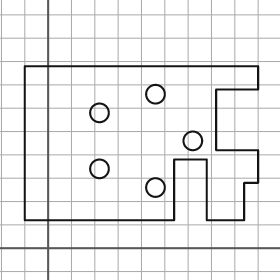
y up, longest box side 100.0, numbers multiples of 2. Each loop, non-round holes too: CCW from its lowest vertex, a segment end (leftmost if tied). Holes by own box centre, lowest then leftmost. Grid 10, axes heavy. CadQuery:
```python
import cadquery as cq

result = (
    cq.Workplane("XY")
    .moveTo(-10.0, 12.0)
    .lineTo(54.0, 12.0)
    .lineTo(54.0, 38.0)
    .lineTo(68.0, 38.0)
    .lineTo(68.0, 12.0)
    .lineTo(84.0, 12.0)
    .lineTo(84.0, 28.0)
    .lineTo(90.0, 28.0)
    .lineTo(90.0, 42.0)
    .lineTo(72.0, 42.0)
    .lineTo(72.0, 68.0)
    .lineTo(90.0, 68.0)
    .lineTo(90.0, 78.0)
    .lineTo(-10.0, 78.0)
    .close()
    .moveTo(46.0, 26.0)
    .circle(4.0)
    .moveTo(22.0, 34.0)
    .circle(4.0)
    .moveTo(62.0, 46.0)
    .circle(4.0)
    .moveTo(22.0, 58.0)
    .circle(4.0)
    .moveTo(46.0, 66.0)
    .circle(4.0)
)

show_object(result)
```